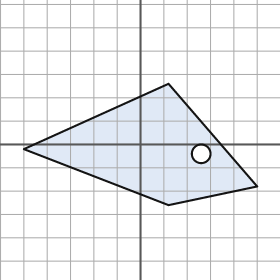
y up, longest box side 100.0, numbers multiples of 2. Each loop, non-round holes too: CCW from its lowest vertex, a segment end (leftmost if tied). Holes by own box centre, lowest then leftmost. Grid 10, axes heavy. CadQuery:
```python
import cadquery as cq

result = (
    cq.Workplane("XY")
    .moveTo(12.0, -26.0)
    .lineTo(50.0, -18.0)
    .lineTo(12.0, 26.0)
    .lineTo(-50.0, -2.0)
    .close()
    .moveTo(26.0, -4.0)
    .circle(4.0)
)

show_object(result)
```